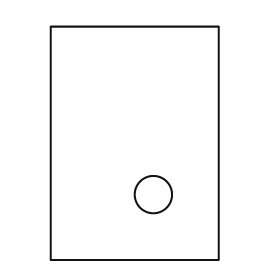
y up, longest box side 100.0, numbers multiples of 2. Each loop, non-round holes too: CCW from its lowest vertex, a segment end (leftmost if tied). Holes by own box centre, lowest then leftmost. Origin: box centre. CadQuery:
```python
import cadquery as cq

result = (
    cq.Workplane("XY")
    .moveTo(-36.0, -50.0)
    .lineTo(36.0, -50.0)
    .lineTo(36.0, 50.0)
    .lineTo(-36.0, 50.0)
    .close()
    .moveTo(8.0, -22.0)
    .circle(8.0)
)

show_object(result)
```